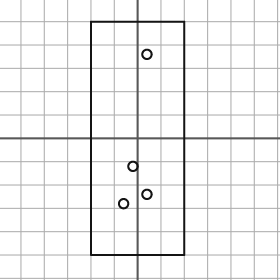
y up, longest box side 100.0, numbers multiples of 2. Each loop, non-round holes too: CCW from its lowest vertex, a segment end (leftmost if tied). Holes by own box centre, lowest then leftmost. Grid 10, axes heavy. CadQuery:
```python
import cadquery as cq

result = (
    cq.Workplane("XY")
    .moveTo(-20.0, -50.0)
    .lineTo(20.0, -50.0)
    .lineTo(20.0, 50.0)
    .lineTo(-20.0, 50.0)
    .close()
    .moveTo(-6.0, -28.0)
    .circle(2.0)
    .moveTo(4.0, -24.0)
    .circle(2.0)
    .moveTo(-2.0, -12.0)
    .circle(2.0)
    .moveTo(4.0, 36.0)
    .circle(2.0)
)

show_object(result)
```